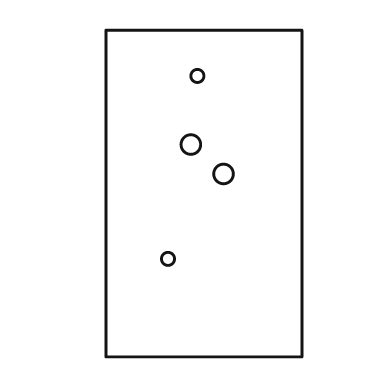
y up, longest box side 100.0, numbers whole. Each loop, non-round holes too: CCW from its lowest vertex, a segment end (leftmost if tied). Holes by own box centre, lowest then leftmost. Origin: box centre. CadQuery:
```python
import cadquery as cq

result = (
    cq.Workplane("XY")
    .moveTo(-30.0, -50.0)
    .lineTo(30.0, -50.0)
    .lineTo(30.0, 50.0)
    .lineTo(-30.0, 50.0)
    .close()
    .moveTo(-11.0, -20.0)
    .circle(2.0)
    .moveTo(6.0, 6.0)
    .circle(3.0)
    .moveTo(-4.0, 15.0)
    .circle(3.0)
    .moveTo(-2.0, 36.0)
    .circle(2.0)
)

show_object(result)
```